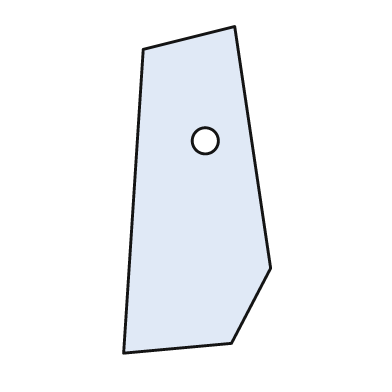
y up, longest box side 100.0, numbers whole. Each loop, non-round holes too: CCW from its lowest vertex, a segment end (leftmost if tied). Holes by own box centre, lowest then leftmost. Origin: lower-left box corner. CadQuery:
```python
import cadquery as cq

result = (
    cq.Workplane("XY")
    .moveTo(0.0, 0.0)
    .lineTo(33.0, 3.0)
    .lineTo(45.0, 26.0)
    .lineTo(34.0, 100.0)
    .lineTo(6.0, 93.0)
    .close()
    .moveTo(25.0, 65.0)
    .circle(4.0)
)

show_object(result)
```